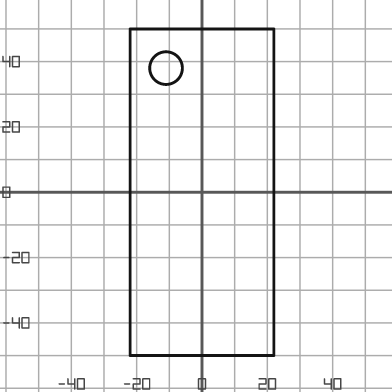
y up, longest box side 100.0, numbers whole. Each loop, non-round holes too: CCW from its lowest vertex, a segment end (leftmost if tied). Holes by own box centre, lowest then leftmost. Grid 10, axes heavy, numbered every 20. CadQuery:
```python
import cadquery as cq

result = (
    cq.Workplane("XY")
    .moveTo(-22.0, -50.0)
    .lineTo(22.0, -50.0)
    .lineTo(22.0, 50.0)
    .lineTo(-22.0, 50.0)
    .close()
    .moveTo(-11.0, 38.0)
    .circle(5.0)
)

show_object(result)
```